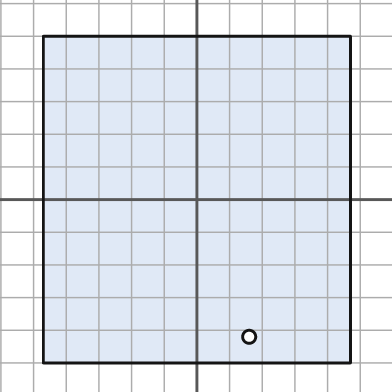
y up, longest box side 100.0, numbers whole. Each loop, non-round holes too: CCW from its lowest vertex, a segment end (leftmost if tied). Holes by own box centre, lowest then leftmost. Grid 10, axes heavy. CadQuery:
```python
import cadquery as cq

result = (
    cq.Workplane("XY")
    .moveTo(-47.0, -50.0)
    .lineTo(47.0, -50.0)
    .lineTo(47.0, 50.0)
    .lineTo(-47.0, 50.0)
    .close()
    .moveTo(16.0, -42.0)
    .circle(2.0)
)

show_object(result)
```